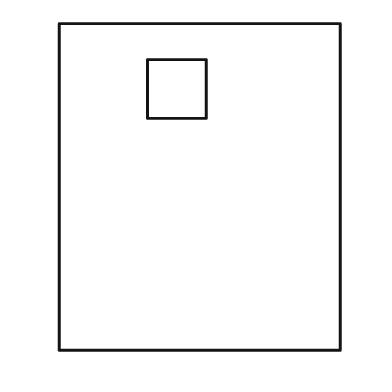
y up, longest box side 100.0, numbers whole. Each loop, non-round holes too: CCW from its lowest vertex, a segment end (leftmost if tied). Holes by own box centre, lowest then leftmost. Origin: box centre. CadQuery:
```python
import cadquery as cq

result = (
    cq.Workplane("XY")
    .moveTo(-43.0, -50.0)
    .lineTo(43.0, -50.0)
    .lineTo(43.0, 50.0)
    .lineTo(-43.0, 50.0)
    .close()
    .moveTo(-16.0, 21.0)
    .lineTo(2.0, 21.0)
    .lineTo(2.0, 39.0)
    .lineTo(-16.0, 39.0)
    .close()
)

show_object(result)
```